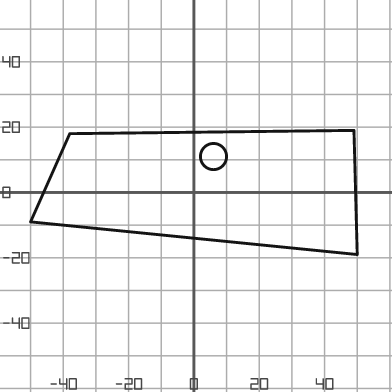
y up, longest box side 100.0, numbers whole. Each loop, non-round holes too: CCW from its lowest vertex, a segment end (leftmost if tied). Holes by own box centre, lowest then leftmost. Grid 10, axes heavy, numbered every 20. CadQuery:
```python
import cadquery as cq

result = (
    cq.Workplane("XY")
    .moveTo(50.0, -19.0)
    .lineTo(49.0, 19.0)
    .lineTo(-38.0, 18.0)
    .lineTo(-50.0, -9.0)
    .close()
    .moveTo(6.0, 11.0)
    .circle(4.0)
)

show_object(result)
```